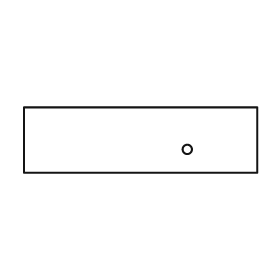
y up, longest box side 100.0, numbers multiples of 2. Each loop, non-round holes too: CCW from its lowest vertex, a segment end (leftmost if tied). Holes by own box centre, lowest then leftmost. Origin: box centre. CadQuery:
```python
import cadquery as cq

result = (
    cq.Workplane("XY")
    .moveTo(-50.0, -14.0)
    .lineTo(50.0, -14.0)
    .lineTo(50.0, 14.0)
    .lineTo(-50.0, 14.0)
    .close()
    .moveTo(20.0, -4.0)
    .circle(2.0)
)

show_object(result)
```